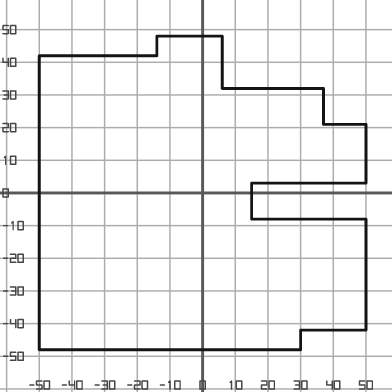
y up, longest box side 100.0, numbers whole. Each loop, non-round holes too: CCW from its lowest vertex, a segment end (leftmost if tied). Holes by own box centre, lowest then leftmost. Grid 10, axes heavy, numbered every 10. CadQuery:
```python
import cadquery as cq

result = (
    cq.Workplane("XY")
    .moveTo(-50.0, -48.0)
    .lineTo(30.0, -48.0)
    .lineTo(30.0, -42.0)
    .lineTo(50.0, -42.0)
    .lineTo(50.0, -8.0)
    .lineTo(15.0, -8.0)
    .lineTo(15.0, 3.0)
    .lineTo(50.0, 3.0)
    .lineTo(50.0, 21.0)
    .lineTo(37.0, 21.0)
    .lineTo(37.0, 32.0)
    .lineTo(6.0, 32.0)
    .lineTo(6.0, 48.0)
    .lineTo(-14.0, 48.0)
    .lineTo(-14.0, 42.0)
    .lineTo(-50.0, 42.0)
    .close()
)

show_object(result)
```